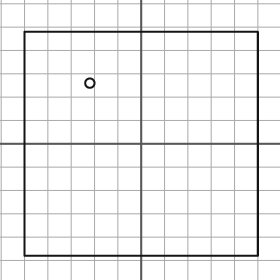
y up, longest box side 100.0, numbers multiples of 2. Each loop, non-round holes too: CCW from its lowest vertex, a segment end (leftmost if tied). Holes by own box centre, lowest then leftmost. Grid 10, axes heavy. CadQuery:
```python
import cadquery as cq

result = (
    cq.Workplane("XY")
    .moveTo(-50.0, -48.0)
    .lineTo(50.0, -48.0)
    .lineTo(50.0, 48.0)
    .lineTo(-50.0, 48.0)
    .close()
    .moveTo(-22.0, 26.0)
    .circle(2.0)
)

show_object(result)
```